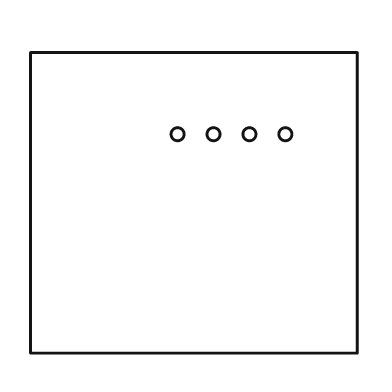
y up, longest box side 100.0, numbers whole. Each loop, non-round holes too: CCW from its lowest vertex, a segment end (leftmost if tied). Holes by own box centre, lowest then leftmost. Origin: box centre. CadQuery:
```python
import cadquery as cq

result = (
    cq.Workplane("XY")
    .moveTo(-50.0, -46.0)
    .lineTo(50.0, -46.0)
    .lineTo(50.0, 46.0)
    .lineTo(-50.0, 46.0)
    .close()
    .moveTo(-5.0, 21.0)
    .circle(2.0)
    .moveTo(6.0, 21.0)
    .circle(2.0)
    .moveTo(17.0, 21.0)
    .circle(2.0)
    .moveTo(28.0, 21.0)
    .circle(2.0)
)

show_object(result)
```